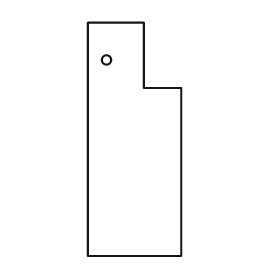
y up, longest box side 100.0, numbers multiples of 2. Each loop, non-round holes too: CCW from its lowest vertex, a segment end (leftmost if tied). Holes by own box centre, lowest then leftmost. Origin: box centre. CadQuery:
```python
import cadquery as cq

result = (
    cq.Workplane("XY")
    .moveTo(-20.0, -50.0)
    .lineTo(20.0, -50.0)
    .lineTo(20.0, 22.0)
    .lineTo(4.0, 22.0)
    .lineTo(4.0, 50.0)
    .lineTo(-20.0, 50.0)
    .close()
    .moveTo(-12.0, 34.0)
    .circle(2.0)
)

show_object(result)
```